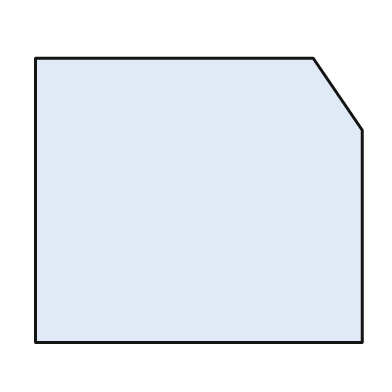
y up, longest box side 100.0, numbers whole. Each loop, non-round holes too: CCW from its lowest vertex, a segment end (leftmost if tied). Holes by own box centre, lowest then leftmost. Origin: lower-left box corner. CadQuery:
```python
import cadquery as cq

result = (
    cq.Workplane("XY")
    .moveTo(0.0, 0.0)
    .lineTo(100.0, 0.0)
    .lineTo(100.0, 65.0)
    .lineTo(85.0, 87.0)
    .lineTo(0.0, 87.0)
    .close()
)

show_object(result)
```